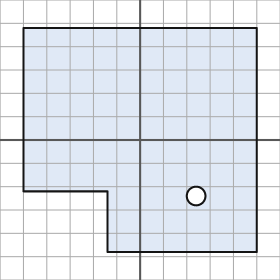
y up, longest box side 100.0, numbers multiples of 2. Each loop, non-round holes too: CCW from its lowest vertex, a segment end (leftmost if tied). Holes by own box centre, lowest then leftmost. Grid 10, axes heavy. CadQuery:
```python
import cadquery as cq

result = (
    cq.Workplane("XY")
    .moveTo(-14.0, -48.0)
    .lineTo(50.0, -48.0)
    .lineTo(50.0, 48.0)
    .lineTo(-50.0, 48.0)
    .lineTo(-50.0, -22.0)
    .lineTo(-14.0, -22.0)
    .close()
    .moveTo(24.0, -24.0)
    .circle(4.0)
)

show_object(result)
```